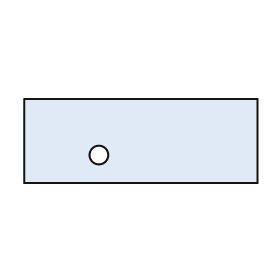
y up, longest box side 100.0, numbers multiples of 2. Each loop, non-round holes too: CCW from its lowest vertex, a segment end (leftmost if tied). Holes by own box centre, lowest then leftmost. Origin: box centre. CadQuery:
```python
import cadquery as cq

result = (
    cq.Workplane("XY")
    .moveTo(-50.0, -18.0)
    .lineTo(50.0, -18.0)
    .lineTo(50.0, 18.0)
    .lineTo(-50.0, 18.0)
    .close()
    .moveTo(-18.0, -6.0)
    .circle(4.0)
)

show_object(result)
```